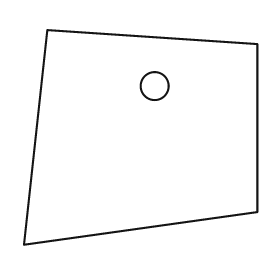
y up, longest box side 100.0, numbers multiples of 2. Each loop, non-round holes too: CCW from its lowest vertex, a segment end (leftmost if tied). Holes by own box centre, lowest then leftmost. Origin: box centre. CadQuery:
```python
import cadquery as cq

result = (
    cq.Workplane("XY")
    .moveTo(-50.0, -46.0)
    .lineTo(50.0, -32.0)
    .lineTo(50.0, 40.0)
    .lineTo(-40.0, 46.0)
    .close()
    .moveTo(6.0, 22.0)
    .circle(6.0)
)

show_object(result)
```